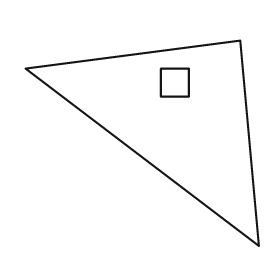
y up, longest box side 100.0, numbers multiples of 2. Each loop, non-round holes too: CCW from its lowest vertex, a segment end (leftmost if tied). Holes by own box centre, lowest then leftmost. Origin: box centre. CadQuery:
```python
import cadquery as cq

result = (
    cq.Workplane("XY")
    .moveTo(50.0, -44.0)
    .lineTo(42.0, 44.0)
    .lineTo(-50.0, 32.0)
    .close()
    .moveTo(8.0, 20.0)
    .lineTo(20.0, 20.0)
    .lineTo(20.0, 32.0)
    .lineTo(8.0, 32.0)
    .close()
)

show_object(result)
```